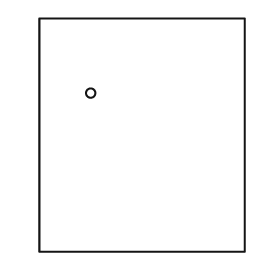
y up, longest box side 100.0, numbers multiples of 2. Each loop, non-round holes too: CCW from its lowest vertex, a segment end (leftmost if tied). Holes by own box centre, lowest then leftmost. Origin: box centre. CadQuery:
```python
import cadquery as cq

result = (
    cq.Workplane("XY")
    .moveTo(-44.0, -50.0)
    .lineTo(44.0, -50.0)
    .lineTo(44.0, 50.0)
    .lineTo(-44.0, 50.0)
    .close()
    .moveTo(-22.0, 18.0)
    .circle(2.0)
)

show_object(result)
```